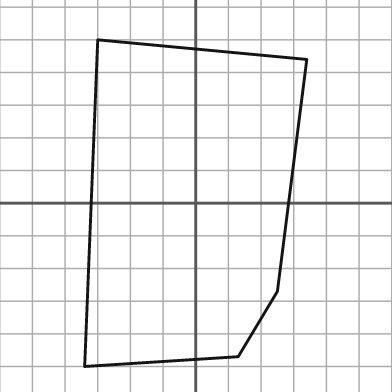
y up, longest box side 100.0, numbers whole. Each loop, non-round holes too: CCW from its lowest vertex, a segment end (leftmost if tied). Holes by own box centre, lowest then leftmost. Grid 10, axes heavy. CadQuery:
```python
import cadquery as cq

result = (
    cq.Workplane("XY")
    .moveTo(-34.0, -50.0)
    .lineTo(13.0, -47.0)
    .lineTo(25.0, -27.0)
    .lineTo(34.0, 44.0)
    .lineTo(-30.0, 50.0)
    .close()
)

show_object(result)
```